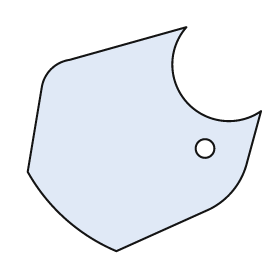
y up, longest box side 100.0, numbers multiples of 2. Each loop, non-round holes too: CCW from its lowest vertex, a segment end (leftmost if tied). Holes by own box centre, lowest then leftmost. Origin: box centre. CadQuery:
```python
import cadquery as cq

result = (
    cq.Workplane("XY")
    .moveTo(-12.0, -48.0)
    .lineTo(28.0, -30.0)
    .threePointArc((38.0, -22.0), (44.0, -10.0))
    .lineTo(50.0, 12.0)
    .threePointArc((18.0, 16.0), (18.0, 48.0))
    .lineTo(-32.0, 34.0)
    .threePointArc((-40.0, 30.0), (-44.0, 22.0))
    .lineTo(-50.0, -14.0)
    .threePointArc((-34.0, -34.0), (-12.0, -48.0))
    .close()
    .moveTo(26.0, -4.0)
    .circle(4.0)
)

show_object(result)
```